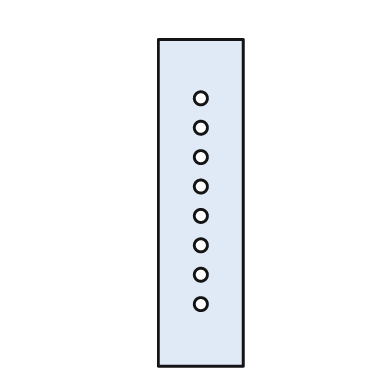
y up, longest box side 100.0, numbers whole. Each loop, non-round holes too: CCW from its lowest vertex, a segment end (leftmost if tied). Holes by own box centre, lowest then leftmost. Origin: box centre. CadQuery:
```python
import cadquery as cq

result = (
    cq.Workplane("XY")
    .moveTo(-13.0, -50.0)
    .lineTo(13.0, -50.0)
    .lineTo(13.0, 50.0)
    .lineTo(-13.0, 50.0)
    .close()
    .moveTo(0.0, -31.0)
    .circle(2.0)
    .moveTo(0.0, -22.0)
    .circle(2.0)
    .moveTo(0.0, -13.0)
    .circle(2.0)
    .moveTo(0.0, -4.0)
    .circle(2.0)
    .moveTo(0.0, 5.0)
    .circle(2.0)
    .moveTo(0.0, 14.0)
    .circle(2.0)
    .moveTo(0.0, 23.0)
    .circle(2.0)
    .moveTo(0.0, 32.0)
    .circle(2.0)
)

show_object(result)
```